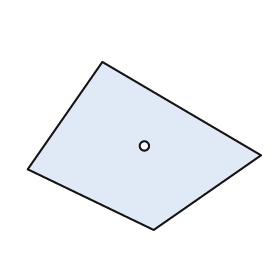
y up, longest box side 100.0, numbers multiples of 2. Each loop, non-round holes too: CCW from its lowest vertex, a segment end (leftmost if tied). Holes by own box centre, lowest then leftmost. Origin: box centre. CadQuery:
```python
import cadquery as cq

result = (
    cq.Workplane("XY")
    .moveTo(4.0, -36.0)
    .lineTo(50.0, -4.0)
    .lineTo(-18.0, 36.0)
    .lineTo(-50.0, -10.0)
    .close()
    .moveTo(0.0, 0.0)
    .circle(2.0)
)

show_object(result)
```